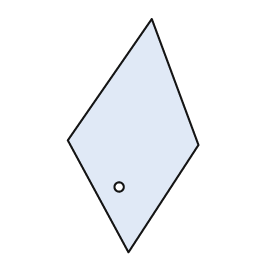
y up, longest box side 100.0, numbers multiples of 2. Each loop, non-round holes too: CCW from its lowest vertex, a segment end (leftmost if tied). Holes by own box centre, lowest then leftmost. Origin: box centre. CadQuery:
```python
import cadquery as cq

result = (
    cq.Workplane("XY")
    .moveTo(-2.0, -50.0)
    .lineTo(28.0, -4.0)
    .lineTo(8.0, 50.0)
    .lineTo(-28.0, -2.0)
    .close()
    .moveTo(-6.0, -22.0)
    .circle(2.0)
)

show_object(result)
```